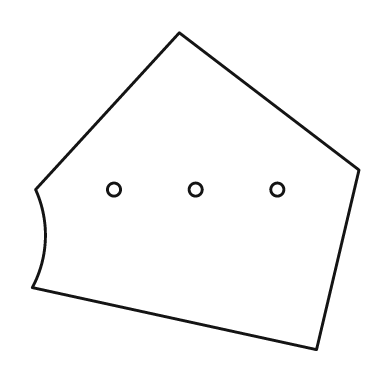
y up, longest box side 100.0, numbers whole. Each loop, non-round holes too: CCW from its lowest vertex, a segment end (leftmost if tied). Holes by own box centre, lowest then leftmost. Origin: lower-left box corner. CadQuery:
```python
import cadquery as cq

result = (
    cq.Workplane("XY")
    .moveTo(87.0, 0.0)
    .lineTo(100.0, 55.0)
    .lineTo(45.0, 97.0)
    .lineTo(1.0, 49.0)
    .threePointArc((4.0, 34.0), (0.0, 19.0))
    .close()
    .moveTo(25.0, 49.0)
    .circle(2.0)
    .moveTo(50.0, 49.0)
    .circle(2.0)
    .moveTo(75.0, 49.0)
    .circle(2.0)
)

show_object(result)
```